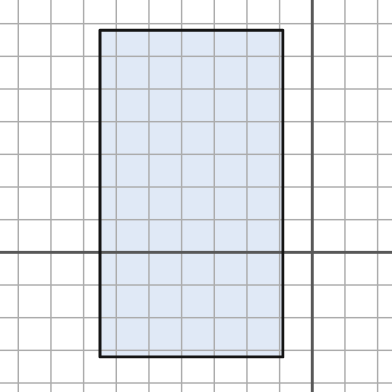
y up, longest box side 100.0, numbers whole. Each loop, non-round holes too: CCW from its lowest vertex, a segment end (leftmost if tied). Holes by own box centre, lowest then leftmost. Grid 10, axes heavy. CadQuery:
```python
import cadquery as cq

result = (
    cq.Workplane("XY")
    .moveTo(-65.0, -32.0)
    .lineTo(-9.0, -32.0)
    .lineTo(-9.0, 68.0)
    .lineTo(-65.0, 68.0)
    .close()
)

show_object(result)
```